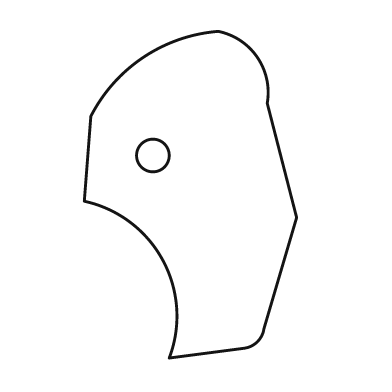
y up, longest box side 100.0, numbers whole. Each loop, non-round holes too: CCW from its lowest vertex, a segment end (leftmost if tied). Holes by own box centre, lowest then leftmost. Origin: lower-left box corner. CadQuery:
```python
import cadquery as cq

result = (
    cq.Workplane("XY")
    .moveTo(26.0, 0.0)
    .lineTo(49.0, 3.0)
    .threePointArc((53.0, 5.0), (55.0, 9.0))
    .lineTo(65.0, 43.0)
    .lineTo(56.0, 78.0)
    .threePointArc((53.0, 92.0), (41.0, 100.0))
    .threePointArc((18.0, 92.0), (2.0, 74.0))
    .lineTo(0.0, 48.0)
    .threePointArc((24.0, 30.0), (26.0, 0.0))
    .close()
    .moveTo(21.0, 62.0)
    .circle(5.0)
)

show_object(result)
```